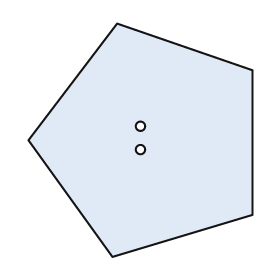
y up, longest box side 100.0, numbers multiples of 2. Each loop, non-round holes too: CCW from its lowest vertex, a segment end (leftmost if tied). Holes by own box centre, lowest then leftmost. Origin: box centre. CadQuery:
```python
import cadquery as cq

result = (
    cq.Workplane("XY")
    .moveTo(-12.0, -50.0)
    .lineTo(48.0, -32.0)
    .lineTo(48.0, 30.0)
    .lineTo(-10.0, 50.0)
    .lineTo(-48.0, 0.0)
    .close()
    .moveTo(0.0, -4.0)
    .circle(2.0)
    .moveTo(0.0, 6.0)
    .circle(2.0)
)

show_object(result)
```